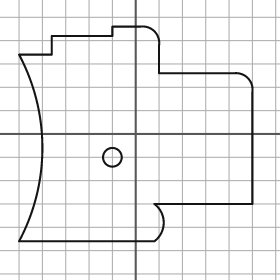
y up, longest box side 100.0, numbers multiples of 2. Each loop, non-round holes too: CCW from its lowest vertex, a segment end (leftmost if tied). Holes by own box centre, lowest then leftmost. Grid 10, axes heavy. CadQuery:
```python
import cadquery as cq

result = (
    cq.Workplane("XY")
    .moveTo(-50.0, -46.0)
    .lineTo(8.0, -46.0)
    .threePointArc((12.0, -38.0), (8.0, -30.0))
    .lineTo(50.0, -30.0)
    .lineTo(50.0, 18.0)
    .threePointArc((48.0, 24.0), (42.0, 26.0))
    .lineTo(10.0, 26.0)
    .lineTo(10.0, 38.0)
    .threePointArc((8.0, 44.0), (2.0, 46.0))
    .lineTo(-10.0, 46.0)
    .lineTo(-10.0, 42.0)
    .lineTo(-36.0, 42.0)
    .lineTo(-36.0, 34.0)
    .lineTo(-50.0, 34.0)
    .threePointArc((-40.0, -6.0), (-50.0, -46.0))
    .close()
    .moveTo(-10.0, -10.0)
    .circle(4.0)
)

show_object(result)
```